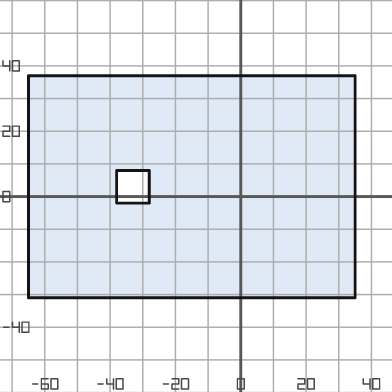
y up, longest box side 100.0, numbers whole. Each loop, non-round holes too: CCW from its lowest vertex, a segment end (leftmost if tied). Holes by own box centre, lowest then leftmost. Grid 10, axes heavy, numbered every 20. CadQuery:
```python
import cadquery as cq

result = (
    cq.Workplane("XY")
    .moveTo(-65.0, -31.0)
    .lineTo(35.0, -31.0)
    .lineTo(35.0, 37.0)
    .lineTo(-65.0, 37.0)
    .close()
    .moveTo(-38.0, -2.0)
    .lineTo(-28.0, -2.0)
    .lineTo(-28.0, 8.0)
    .lineTo(-38.0, 8.0)
    .close()
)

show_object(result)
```